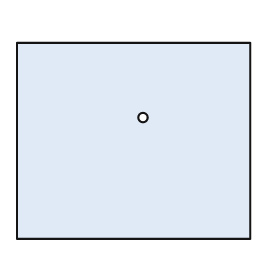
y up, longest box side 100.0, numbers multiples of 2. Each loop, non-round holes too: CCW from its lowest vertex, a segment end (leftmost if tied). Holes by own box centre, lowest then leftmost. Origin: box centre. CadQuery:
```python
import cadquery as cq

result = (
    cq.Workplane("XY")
    .moveTo(-50.0, -42.0)
    .lineTo(50.0, -42.0)
    .lineTo(50.0, 42.0)
    .lineTo(-50.0, 42.0)
    .close()
    .moveTo(4.0, 10.0)
    .circle(2.0)
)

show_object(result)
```